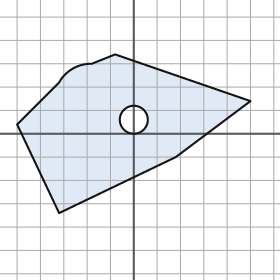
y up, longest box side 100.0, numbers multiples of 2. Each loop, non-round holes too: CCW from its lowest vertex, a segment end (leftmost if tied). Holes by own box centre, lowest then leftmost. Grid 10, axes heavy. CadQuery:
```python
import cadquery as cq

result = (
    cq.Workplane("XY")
    .moveTo(-32.0, -34.0)
    .lineTo(18.0, -10.0)
    .lineTo(50.0, 14.0)
    .lineTo(-8.0, 34.0)
    .lineTo(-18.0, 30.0)
    .threePointArc((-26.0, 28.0), (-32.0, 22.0))
    .lineTo(-50.0, 4.0)
    .close()
    .moveTo(0.0, 6.0)
    .circle(6.0)
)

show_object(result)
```